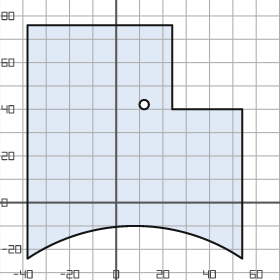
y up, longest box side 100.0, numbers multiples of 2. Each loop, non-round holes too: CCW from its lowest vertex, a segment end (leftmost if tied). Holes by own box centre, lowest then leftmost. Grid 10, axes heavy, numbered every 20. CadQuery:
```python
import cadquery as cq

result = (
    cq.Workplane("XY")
    .moveTo(-38.0, -24.0)
    .threePointArc((8.0, -10.0), (54.0, -24.0))
    .lineTo(54.0, 40.0)
    .lineTo(24.0, 40.0)
    .lineTo(24.0, 76.0)
    .lineTo(-38.0, 76.0)
    .close()
    .moveTo(12.0, 42.0)
    .circle(2.0)
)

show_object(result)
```